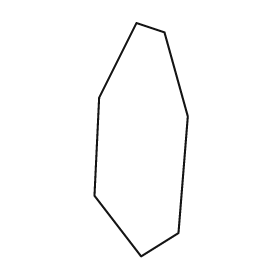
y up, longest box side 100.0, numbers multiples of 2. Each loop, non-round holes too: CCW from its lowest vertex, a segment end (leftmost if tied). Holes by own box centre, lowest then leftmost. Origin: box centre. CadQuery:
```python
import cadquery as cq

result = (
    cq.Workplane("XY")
    .moveTo(0.0, -50.0)
    .lineTo(16.0, -40.0)
    .lineTo(20.0, 10.0)
    .lineTo(10.0, 46.0)
    .lineTo(-2.0, 50.0)
    .lineTo(-18.0, 18.0)
    .lineTo(-20.0, -24.0)
    .close()
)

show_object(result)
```